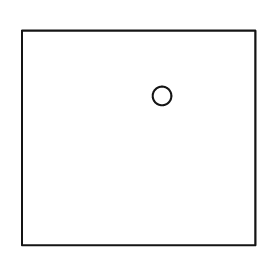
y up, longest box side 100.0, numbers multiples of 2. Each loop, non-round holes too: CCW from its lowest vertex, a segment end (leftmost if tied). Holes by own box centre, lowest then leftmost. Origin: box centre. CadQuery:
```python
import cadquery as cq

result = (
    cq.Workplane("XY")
    .moveTo(-50.0, -46.0)
    .lineTo(50.0, -46.0)
    .lineTo(50.0, 46.0)
    .lineTo(-50.0, 46.0)
    .close()
    .moveTo(10.0, 18.0)
    .circle(4.0)
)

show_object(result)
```